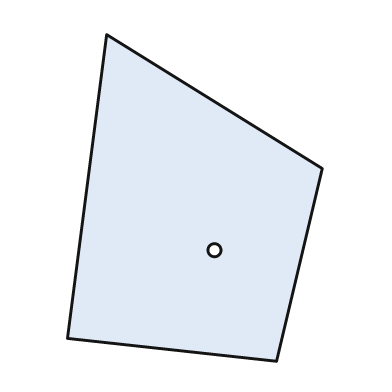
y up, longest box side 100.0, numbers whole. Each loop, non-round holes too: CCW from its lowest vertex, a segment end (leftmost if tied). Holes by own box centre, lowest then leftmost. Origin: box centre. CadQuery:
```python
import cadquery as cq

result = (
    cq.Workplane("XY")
    .moveTo(25.0, -50.0)
    .lineTo(39.0, 9.0)
    .lineTo(-27.0, 50.0)
    .lineTo(-39.0, -43.0)
    .close()
    .moveTo(6.0, -16.0)
    .circle(2.0)
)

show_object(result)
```